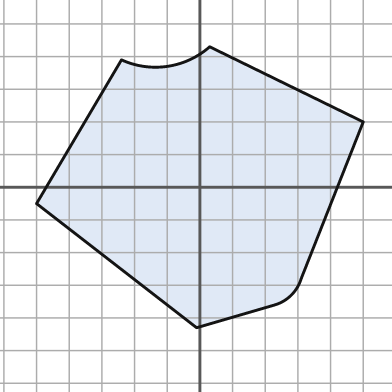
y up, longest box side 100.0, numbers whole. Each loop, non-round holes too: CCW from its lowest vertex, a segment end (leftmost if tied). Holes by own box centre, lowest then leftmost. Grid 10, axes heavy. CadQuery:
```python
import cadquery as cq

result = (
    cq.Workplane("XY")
    .moveTo(-1.0, -43.0)
    .lineTo(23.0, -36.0)
    .threePointArc((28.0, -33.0), (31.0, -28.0))
    .lineTo(50.0, 20.0)
    .lineTo(3.0, 43.0)
    .threePointArc((-10.0, 37.0), (-24.0, 39.0))
    .lineTo(-50.0, -5.0)
    .close()
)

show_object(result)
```